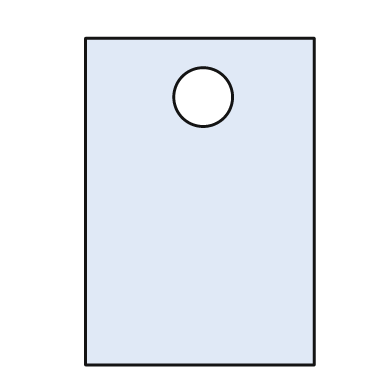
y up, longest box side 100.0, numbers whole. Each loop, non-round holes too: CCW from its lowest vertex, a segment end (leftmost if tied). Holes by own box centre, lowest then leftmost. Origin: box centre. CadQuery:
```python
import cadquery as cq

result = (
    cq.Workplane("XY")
    .moveTo(-35.0, -50.0)
    .lineTo(35.0, -50.0)
    .lineTo(35.0, 50.0)
    .lineTo(-35.0, 50.0)
    .close()
    .moveTo(1.0, 32.0)
    .circle(9.0)
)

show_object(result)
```